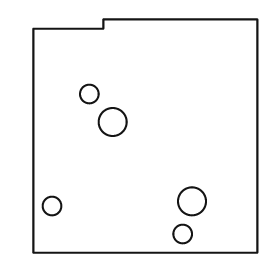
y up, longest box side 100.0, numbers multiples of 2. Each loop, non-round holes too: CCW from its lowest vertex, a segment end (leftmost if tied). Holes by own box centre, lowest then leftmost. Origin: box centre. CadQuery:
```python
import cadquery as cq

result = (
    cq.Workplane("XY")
    .moveTo(-48.0, -50.0)
    .lineTo(48.0, -50.0)
    .lineTo(48.0, 50.0)
    .lineTo(-18.0, 50.0)
    .lineTo(-18.0, 46.0)
    .lineTo(-48.0, 46.0)
    .close()
    .moveTo(16.0, -42.0)
    .circle(4.0)
    .moveTo(-40.0, -30.0)
    .circle(4.0)
    .moveTo(20.0, -28.0)
    .circle(6.0)
    .moveTo(-14.0, 6.0)
    .circle(6.0)
    .moveTo(-24.0, 18.0)
    .circle(4.0)
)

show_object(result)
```